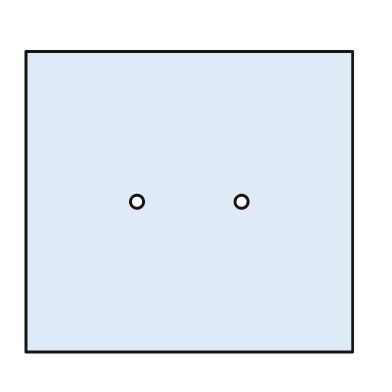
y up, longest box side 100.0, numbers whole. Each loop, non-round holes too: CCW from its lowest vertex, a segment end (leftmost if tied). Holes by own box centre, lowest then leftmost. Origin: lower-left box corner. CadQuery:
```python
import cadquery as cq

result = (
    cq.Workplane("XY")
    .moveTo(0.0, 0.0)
    .lineTo(100.0, 0.0)
    .lineTo(100.0, 92.0)
    .lineTo(0.0, 92.0)
    .close()
    .moveTo(34.0, 46.0)
    .circle(2.0)
    .moveTo(66.0, 46.0)
    .circle(2.0)
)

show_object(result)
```